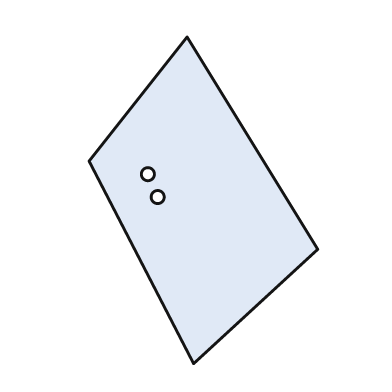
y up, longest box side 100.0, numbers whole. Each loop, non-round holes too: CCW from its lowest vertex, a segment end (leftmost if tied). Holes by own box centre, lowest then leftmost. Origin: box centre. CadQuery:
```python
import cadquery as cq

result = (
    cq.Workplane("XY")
    .moveTo(-3.0, -50.0)
    .lineTo(35.0, -15.0)
    .lineTo(-5.0, 50.0)
    .lineTo(-35.0, 12.0)
    .close()
    .moveTo(-14.0, 1.0)
    .circle(2.0)
    .moveTo(-17.0, 8.0)
    .circle(2.0)
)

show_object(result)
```